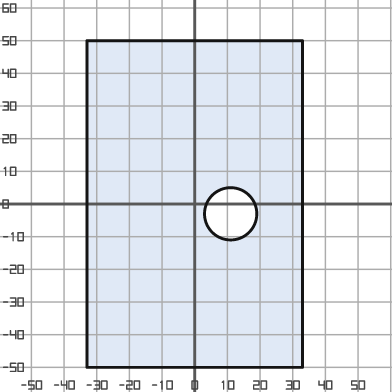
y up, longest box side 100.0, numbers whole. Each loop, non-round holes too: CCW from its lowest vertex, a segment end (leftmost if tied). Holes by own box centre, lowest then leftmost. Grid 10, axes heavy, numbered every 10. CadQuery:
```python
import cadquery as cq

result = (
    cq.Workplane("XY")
    .moveTo(-33.0, -50.0)
    .lineTo(33.0, -50.0)
    .lineTo(33.0, 50.0)
    .lineTo(-33.0, 50.0)
    .close()
    .moveTo(11.0, -3.0)
    .circle(8.0)
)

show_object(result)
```